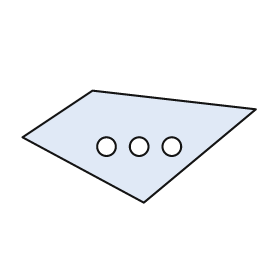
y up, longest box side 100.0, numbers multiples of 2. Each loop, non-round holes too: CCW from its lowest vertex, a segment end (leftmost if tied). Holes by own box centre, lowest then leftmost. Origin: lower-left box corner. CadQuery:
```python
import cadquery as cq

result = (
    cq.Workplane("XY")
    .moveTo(52.0, 0.0)
    .lineTo(100.0, 40.0)
    .lineTo(30.0, 48.0)
    .lineTo(0.0, 28.0)
    .close()
    .moveTo(36.0, 24.0)
    .circle(4.0)
    .moveTo(50.0, 24.0)
    .circle(4.0)
    .moveTo(64.0, 24.0)
    .circle(4.0)
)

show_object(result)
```